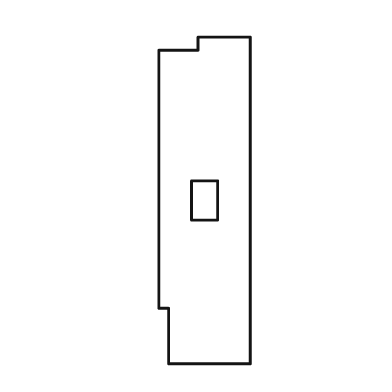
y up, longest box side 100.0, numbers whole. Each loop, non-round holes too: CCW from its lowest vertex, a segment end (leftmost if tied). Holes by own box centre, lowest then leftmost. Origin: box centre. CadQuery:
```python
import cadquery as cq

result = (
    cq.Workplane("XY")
    .moveTo(-11.0, -50.0)
    .lineTo(14.0, -50.0)
    .lineTo(14.0, 50.0)
    .lineTo(-2.0, 50.0)
    .lineTo(-2.0, 46.0)
    .lineTo(-14.0, 46.0)
    .lineTo(-14.0, -33.0)
    .lineTo(-11.0, -33.0)
    .close()
    .moveTo(-4.0, -6.0)
    .lineTo(4.0, -6.0)
    .lineTo(4.0, 6.0)
    .lineTo(-4.0, 6.0)
    .close()
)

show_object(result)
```